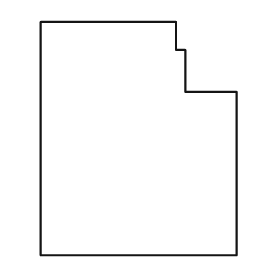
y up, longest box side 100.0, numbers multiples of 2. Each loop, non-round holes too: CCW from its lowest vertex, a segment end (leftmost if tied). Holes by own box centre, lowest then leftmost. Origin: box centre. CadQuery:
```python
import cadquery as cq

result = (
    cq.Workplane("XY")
    .moveTo(-42.0, -50.0)
    .lineTo(42.0, -50.0)
    .lineTo(42.0, 20.0)
    .lineTo(20.0, 20.0)
    .lineTo(20.0, 38.0)
    .lineTo(16.0, 38.0)
    .lineTo(16.0, 50.0)
    .lineTo(-42.0, 50.0)
    .close()
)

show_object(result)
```